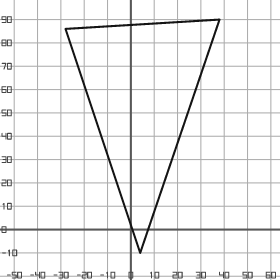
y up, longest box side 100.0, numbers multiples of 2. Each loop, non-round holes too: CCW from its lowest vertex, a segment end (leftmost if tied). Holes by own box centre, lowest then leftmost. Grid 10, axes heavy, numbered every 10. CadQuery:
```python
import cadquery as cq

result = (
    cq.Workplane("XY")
    .moveTo(4.0, -10.0)
    .lineTo(38.0, 90.0)
    .lineTo(-28.0, 86.0)
    .close()
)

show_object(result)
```